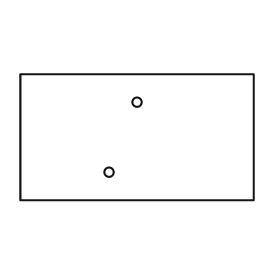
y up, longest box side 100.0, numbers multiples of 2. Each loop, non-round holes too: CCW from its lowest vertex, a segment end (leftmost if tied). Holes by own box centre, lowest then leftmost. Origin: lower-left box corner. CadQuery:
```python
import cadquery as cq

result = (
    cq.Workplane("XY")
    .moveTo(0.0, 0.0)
    .lineTo(100.0, 0.0)
    .lineTo(100.0, 54.0)
    .lineTo(0.0, 54.0)
    .close()
    .moveTo(38.0, 12.0)
    .circle(2.0)
    .moveTo(50.0, 42.0)
    .circle(2.0)
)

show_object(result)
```